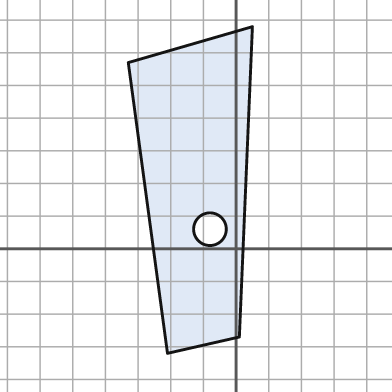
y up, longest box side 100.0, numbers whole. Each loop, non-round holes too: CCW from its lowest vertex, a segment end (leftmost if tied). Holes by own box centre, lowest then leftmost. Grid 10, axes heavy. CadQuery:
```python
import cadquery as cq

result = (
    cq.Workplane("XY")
    .moveTo(-21.0, -32.0)
    .lineTo(1.0, -27.0)
    .lineTo(5.0, 68.0)
    .lineTo(-33.0, 57.0)
    .close()
    .moveTo(-8.0, 6.0)
    .circle(5.0)
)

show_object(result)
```